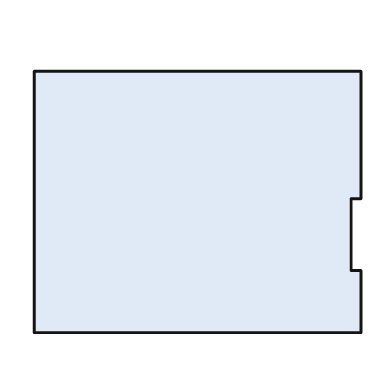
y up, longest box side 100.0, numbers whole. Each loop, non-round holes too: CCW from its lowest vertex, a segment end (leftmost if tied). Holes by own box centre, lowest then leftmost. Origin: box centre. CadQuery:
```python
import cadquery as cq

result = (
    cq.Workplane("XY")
    .moveTo(-50.0, -40.0)
    .lineTo(50.0, -40.0)
    .lineTo(50.0, -21.0)
    .lineTo(47.0, -21.0)
    .lineTo(47.0, 1.0)
    .lineTo(50.0, 1.0)
    .lineTo(50.0, 40.0)
    .lineTo(-50.0, 40.0)
    .close()
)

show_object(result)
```